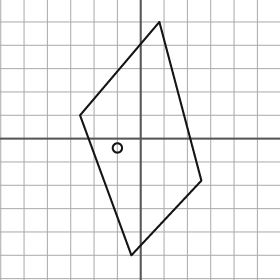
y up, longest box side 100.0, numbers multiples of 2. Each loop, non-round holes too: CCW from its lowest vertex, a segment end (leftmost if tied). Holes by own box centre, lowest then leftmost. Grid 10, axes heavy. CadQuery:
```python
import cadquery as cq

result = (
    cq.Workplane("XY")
    .moveTo(-4.0, -50.0)
    .lineTo(26.0, -18.0)
    .lineTo(8.0, 50.0)
    .lineTo(-26.0, 10.0)
    .close()
    .moveTo(-10.0, -4.0)
    .circle(2.0)
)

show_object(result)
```